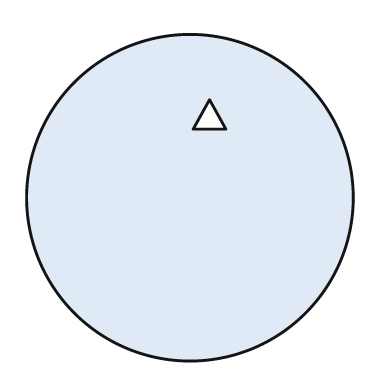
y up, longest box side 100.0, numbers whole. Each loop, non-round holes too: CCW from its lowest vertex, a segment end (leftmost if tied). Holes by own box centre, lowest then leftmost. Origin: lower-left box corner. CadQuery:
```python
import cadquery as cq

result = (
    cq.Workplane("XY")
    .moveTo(50.0, 50.0)
    .circle(50.0)
    .moveTo(51.0, 71.0)
    .lineTo(61.0, 71.0)
    .lineTo(56.0, 80.0)
    .close()
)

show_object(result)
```